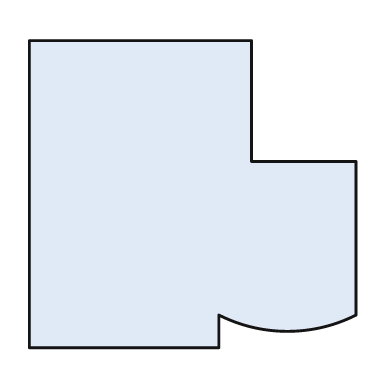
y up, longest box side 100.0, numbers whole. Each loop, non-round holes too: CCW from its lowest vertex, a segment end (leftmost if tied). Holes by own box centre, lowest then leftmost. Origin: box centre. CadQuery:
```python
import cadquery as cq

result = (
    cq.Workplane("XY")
    .moveTo(-50.0, -47.0)
    .lineTo(8.0, -47.0)
    .lineTo(8.0, -37.0)
    .threePointArc((29.0, -42.0), (50.0, -37.0))
    .lineTo(50.0, 10.0)
    .lineTo(18.0, 10.0)
    .lineTo(18.0, 47.0)
    .lineTo(-50.0, 47.0)
    .close()
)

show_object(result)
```